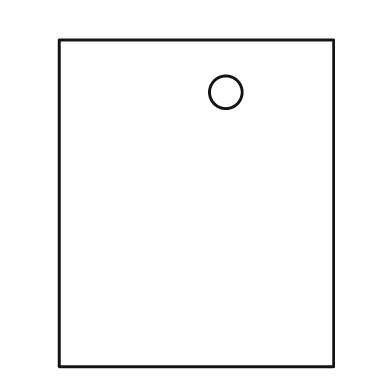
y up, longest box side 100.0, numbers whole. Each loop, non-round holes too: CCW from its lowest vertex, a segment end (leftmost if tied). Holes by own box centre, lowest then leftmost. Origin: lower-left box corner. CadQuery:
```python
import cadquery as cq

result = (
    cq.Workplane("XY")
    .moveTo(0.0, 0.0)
    .lineTo(84.0, 0.0)
    .lineTo(84.0, 100.0)
    .lineTo(0.0, 100.0)
    .close()
    .moveTo(51.0, 84.0)
    .circle(5.0)
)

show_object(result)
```